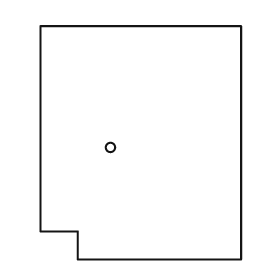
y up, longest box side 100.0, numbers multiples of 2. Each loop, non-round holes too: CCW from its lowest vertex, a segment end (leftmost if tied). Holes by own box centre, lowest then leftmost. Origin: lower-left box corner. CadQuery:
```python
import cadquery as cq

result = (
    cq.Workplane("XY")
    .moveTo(16.0, 0.0)
    .lineTo(86.0, 0.0)
    .lineTo(86.0, 100.0)
    .lineTo(0.0, 100.0)
    .lineTo(0.0, 12.0)
    .lineTo(16.0, 12.0)
    .close()
    .moveTo(30.0, 48.0)
    .circle(2.0)
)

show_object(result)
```